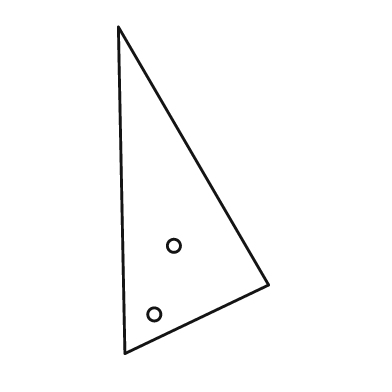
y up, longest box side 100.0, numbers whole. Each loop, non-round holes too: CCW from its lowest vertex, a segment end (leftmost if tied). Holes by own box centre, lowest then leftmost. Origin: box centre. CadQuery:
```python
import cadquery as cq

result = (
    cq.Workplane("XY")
    .moveTo(-21.0, -50.0)
    .lineTo(23.0, -29.0)
    .lineTo(-23.0, 50.0)
    .close()
    .moveTo(-12.0, -38.0)
    .circle(2.0)
    .moveTo(-6.0, -17.0)
    .circle(2.0)
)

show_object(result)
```